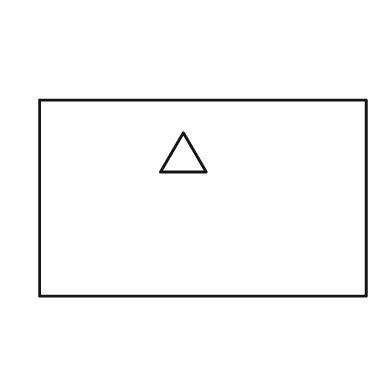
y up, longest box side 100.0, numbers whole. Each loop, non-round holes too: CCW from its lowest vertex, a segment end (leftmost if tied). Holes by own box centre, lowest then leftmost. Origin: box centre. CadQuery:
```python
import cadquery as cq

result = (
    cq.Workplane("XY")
    .moveTo(-50.0, -30.0)
    .lineTo(50.0, -30.0)
    .lineTo(50.0, 30.0)
    .lineTo(-50.0, 30.0)
    .close()
    .moveTo(-13.0, 8.0)
    .lineTo(1.0, 8.0)
    .lineTo(-6.0, 20.0)
    .close()
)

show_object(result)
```